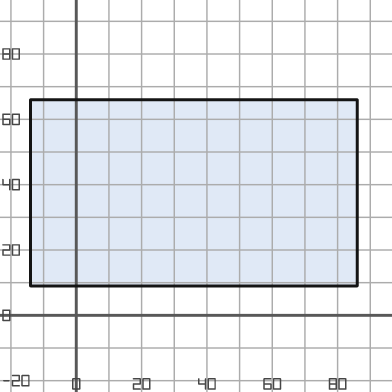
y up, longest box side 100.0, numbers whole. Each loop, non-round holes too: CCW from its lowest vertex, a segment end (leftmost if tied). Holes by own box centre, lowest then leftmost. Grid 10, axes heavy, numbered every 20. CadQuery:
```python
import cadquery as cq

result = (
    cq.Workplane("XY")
    .moveTo(-14.0, 9.0)
    .lineTo(86.0, 9.0)
    .lineTo(86.0, 66.0)
    .lineTo(-14.0, 66.0)
    .close()
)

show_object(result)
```